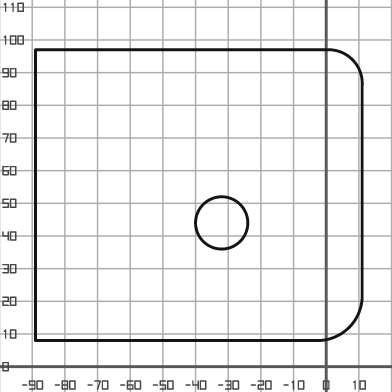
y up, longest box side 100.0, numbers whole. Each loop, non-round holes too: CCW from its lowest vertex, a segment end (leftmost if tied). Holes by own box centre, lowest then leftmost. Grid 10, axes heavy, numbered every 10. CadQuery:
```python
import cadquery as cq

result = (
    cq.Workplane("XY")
    .moveTo(-89.0, 8.0)
    .lineTo(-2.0, 8.0)
    .threePointArc((7.0, 12.0), (11.0, 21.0))
    .lineTo(11.0, 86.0)
    .threePointArc((8.0, 94.0), (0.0, 97.0))
    .lineTo(-89.0, 97.0)
    .close()
    .moveTo(-32.0, 44.0)
    .circle(8.0)
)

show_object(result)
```